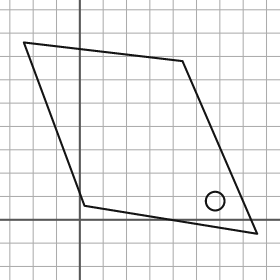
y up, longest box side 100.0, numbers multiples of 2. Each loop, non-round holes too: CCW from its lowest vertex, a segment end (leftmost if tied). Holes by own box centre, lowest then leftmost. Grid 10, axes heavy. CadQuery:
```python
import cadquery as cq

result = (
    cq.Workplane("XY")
    .moveTo(76.0, -6.0)
    .lineTo(44.0, 68.0)
    .lineTo(-24.0, 76.0)
    .lineTo(2.0, 6.0)
    .close()
    .moveTo(58.0, 8.0)
    .circle(4.0)
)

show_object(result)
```